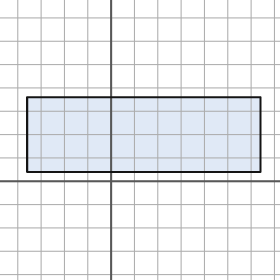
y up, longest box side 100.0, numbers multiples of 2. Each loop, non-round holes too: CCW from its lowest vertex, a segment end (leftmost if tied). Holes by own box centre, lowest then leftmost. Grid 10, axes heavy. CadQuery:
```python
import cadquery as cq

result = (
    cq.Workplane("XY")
    .moveTo(-36.0, 4.0)
    .lineTo(64.0, 4.0)
    .lineTo(64.0, 36.0)
    .lineTo(-36.0, 36.0)
    .close()
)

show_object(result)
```